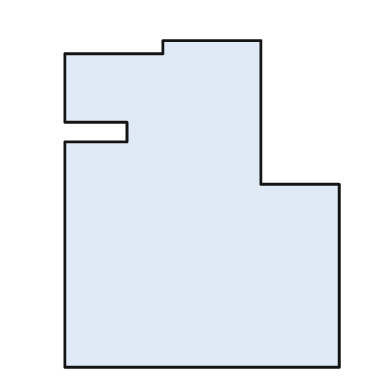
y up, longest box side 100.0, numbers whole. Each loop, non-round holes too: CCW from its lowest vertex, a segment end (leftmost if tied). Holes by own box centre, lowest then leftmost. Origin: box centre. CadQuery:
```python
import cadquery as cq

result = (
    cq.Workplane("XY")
    .moveTo(-42.0, -50.0)
    .lineTo(42.0, -50.0)
    .lineTo(42.0, 6.0)
    .lineTo(18.0, 6.0)
    .lineTo(18.0, 50.0)
    .lineTo(-12.0, 50.0)
    .lineTo(-12.0, 46.0)
    .lineTo(-42.0, 46.0)
    .lineTo(-42.0, 25.0)
    .lineTo(-23.0, 25.0)
    .lineTo(-23.0, 19.0)
    .lineTo(-42.0, 19.0)
    .close()
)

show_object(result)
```